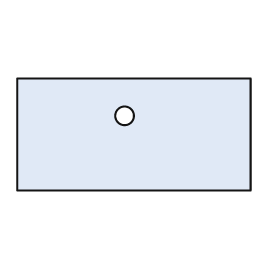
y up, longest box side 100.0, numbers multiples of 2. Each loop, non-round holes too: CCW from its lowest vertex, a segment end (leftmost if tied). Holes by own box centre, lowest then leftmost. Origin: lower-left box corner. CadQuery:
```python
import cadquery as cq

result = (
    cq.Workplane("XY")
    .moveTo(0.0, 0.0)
    .lineTo(100.0, 0.0)
    .lineTo(100.0, 48.0)
    .lineTo(0.0, 48.0)
    .close()
    .moveTo(46.0, 32.0)
    .circle(4.0)
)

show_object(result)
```